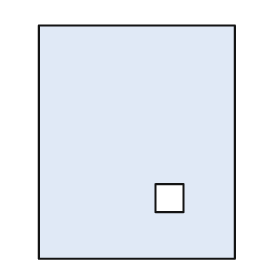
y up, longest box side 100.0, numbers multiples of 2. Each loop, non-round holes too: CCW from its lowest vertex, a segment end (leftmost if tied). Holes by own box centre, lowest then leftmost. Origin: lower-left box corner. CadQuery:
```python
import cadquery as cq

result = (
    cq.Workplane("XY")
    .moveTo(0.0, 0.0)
    .lineTo(84.0, 0.0)
    .lineTo(84.0, 100.0)
    .lineTo(0.0, 100.0)
    .close()
    .moveTo(50.0, 20.0)
    .lineTo(62.0, 20.0)
    .lineTo(62.0, 32.0)
    .lineTo(50.0, 32.0)
    .close()
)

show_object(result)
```